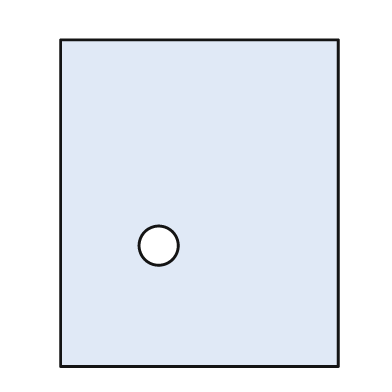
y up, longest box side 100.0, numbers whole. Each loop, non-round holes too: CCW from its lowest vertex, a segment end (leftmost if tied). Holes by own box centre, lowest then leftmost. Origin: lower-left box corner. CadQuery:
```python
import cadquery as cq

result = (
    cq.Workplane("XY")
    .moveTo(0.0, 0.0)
    .lineTo(85.0, 0.0)
    .lineTo(85.0, 100.0)
    .lineTo(0.0, 100.0)
    .close()
    .moveTo(30.0, 37.0)
    .circle(6.0)
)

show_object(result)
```